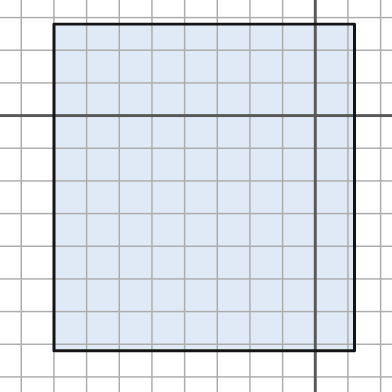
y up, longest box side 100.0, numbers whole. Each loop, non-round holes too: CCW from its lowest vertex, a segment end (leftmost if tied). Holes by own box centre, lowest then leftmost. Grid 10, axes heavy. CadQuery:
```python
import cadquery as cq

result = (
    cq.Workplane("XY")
    .moveTo(-80.0, -72.0)
    .lineTo(12.0, -72.0)
    .lineTo(12.0, 28.0)
    .lineTo(-80.0, 28.0)
    .close()
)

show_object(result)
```